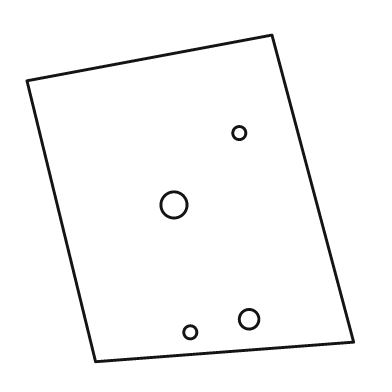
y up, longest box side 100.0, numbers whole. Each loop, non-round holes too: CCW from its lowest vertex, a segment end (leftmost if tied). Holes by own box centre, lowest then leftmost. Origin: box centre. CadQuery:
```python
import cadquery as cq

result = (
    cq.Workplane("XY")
    .moveTo(-29.0, -50.0)
    .lineTo(50.0, -44.0)
    .lineTo(25.0, 50.0)
    .lineTo(-50.0, 36.0)
    .close()
    .moveTo(0.0, -41.0)
    .circle(2.0)
    .moveTo(18.0, -37.0)
    .circle(3.0)
    .moveTo(-5.0, -2.0)
    .circle(4.0)
    .moveTo(15.0, 20.0)
    .circle(2.0)
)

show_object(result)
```